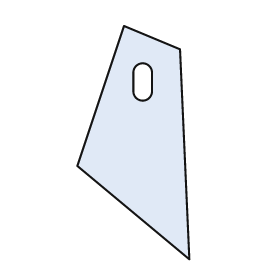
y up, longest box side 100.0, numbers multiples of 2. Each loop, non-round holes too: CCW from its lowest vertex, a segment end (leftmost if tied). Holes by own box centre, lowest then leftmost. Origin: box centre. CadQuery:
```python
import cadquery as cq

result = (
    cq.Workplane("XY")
    .moveTo(24.0, -50.0)
    .lineTo(20.0, 40.0)
    .lineTo(-4.0, 50.0)
    .lineTo(-24.0, -10.0)
    .close()
    .moveTo(0.0, 22.0)
    .threePointArc((4.0, 18.0), (8.0, 22.0))
    .lineTo(8.0, 30.0)
    .threePointArc((4.0, 34.0), (0.0, 30.0))
    .close()
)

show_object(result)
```